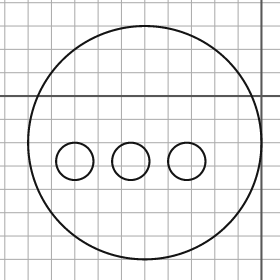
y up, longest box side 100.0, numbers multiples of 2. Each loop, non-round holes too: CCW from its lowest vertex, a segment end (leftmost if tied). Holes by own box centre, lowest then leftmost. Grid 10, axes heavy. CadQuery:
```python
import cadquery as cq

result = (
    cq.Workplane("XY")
    .moveTo(-50.0, -20.0)
    .circle(50.0)
    .moveTo(-80.0, -28.0)
    .circle(8.0)
    .moveTo(-56.0, -28.0)
    .circle(8.0)
    .moveTo(-32.0, -28.0)
    .circle(8.0)
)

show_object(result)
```